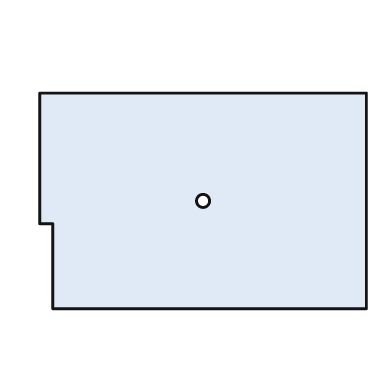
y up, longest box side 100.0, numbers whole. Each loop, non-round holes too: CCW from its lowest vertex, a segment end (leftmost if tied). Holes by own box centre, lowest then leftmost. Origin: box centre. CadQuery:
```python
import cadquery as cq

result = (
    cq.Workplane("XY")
    .moveTo(-46.0, -33.0)
    .lineTo(50.0, -33.0)
    .lineTo(50.0, 33.0)
    .lineTo(-50.0, 33.0)
    .lineTo(-50.0, -7.0)
    .lineTo(-46.0, -7.0)
    .close()
    .moveTo(0.0, 0.0)
    .circle(2.0)
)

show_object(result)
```